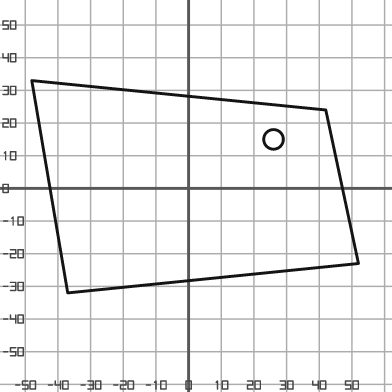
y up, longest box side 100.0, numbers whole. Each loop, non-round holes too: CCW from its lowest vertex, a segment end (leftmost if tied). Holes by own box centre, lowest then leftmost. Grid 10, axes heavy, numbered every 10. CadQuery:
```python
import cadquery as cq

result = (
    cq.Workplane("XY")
    .moveTo(-37.0, -32.0)
    .lineTo(52.0, -23.0)
    .lineTo(42.0, 24.0)
    .lineTo(-48.0, 33.0)
    .close()
    .moveTo(26.0, 15.0)
    .circle(3.0)
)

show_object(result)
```